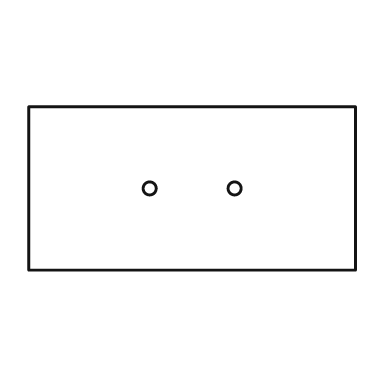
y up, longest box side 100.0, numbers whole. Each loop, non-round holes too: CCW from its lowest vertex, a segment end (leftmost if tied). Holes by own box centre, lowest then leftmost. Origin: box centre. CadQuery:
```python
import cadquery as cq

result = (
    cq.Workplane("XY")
    .moveTo(-50.0, -25.0)
    .lineTo(50.0, -25.0)
    .lineTo(50.0, 25.0)
    .lineTo(-50.0, 25.0)
    .close()
    .moveTo(-13.0, 0.0)
    .circle(2.0)
    .moveTo(13.0, 0.0)
    .circle(2.0)
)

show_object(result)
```